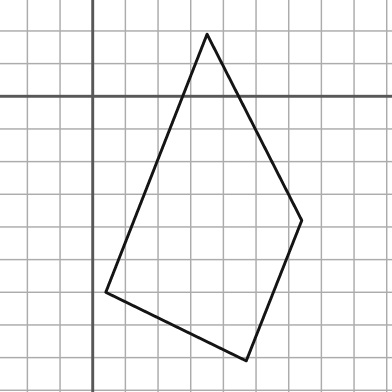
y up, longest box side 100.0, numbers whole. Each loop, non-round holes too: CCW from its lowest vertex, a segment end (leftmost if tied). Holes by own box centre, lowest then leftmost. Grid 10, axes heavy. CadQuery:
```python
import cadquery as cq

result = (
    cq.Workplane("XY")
    .moveTo(47.0, -81.0)
    .lineTo(64.0, -38.0)
    .lineTo(35.0, 19.0)
    .lineTo(4.0, -60.0)
    .close()
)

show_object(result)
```